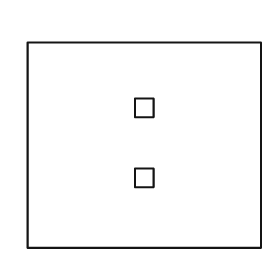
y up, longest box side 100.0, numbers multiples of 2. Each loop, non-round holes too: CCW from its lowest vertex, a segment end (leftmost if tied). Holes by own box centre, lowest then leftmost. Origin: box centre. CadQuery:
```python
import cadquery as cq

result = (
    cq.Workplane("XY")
    .moveTo(-50.0, -44.0)
    .lineTo(50.0, -44.0)
    .lineTo(50.0, 44.0)
    .lineTo(-50.0, 44.0)
    .close()
    .moveTo(-4.0, -18.0)
    .lineTo(4.0, -18.0)
    .lineTo(4.0, -10.0)
    .lineTo(-4.0, -10.0)
    .close()
    .moveTo(-4.0, 12.0)
    .lineTo(4.0, 12.0)
    .lineTo(4.0, 20.0)
    .lineTo(-4.0, 20.0)
    .close()
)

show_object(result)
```